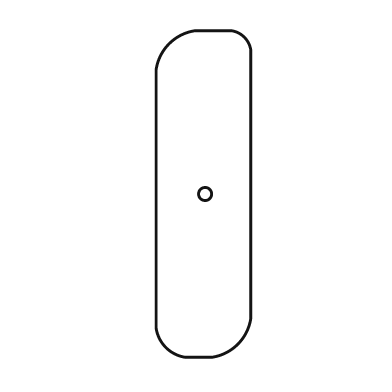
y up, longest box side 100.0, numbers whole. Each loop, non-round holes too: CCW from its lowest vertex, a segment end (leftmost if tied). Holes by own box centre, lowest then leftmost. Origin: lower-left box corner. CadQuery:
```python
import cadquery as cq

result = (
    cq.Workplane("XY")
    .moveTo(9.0, 0.0)
    .lineTo(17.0, 0.0)
    .threePointArc((25.0, 4.0), (29.0, 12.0))
    .lineTo(29.0, 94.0)
    .threePointArc((27.0, 98.0), (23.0, 100.0))
    .lineTo(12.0, 100.0)
    .threePointArc((4.0, 96.0), (0.0, 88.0))
    .lineTo(0.0, 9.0)
    .threePointArc((3.0, 3.0), (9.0, 0.0))
    .close()
    .moveTo(15.0, 50.0)
    .circle(2.0)
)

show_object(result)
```